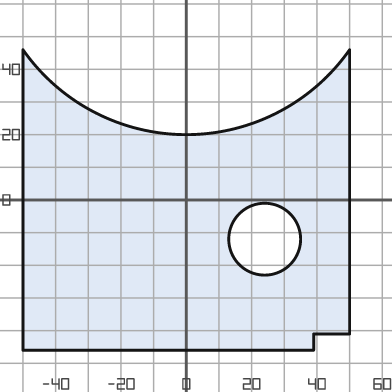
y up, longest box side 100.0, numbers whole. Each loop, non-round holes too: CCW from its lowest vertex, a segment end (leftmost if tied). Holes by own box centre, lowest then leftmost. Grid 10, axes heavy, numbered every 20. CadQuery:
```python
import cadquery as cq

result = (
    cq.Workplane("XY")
    .moveTo(-50.0, -46.0)
    .lineTo(39.0, -46.0)
    .lineTo(39.0, -41.0)
    .lineTo(50.0, -41.0)
    .lineTo(50.0, 46.0)
    .threePointArc((0.0, 20.0), (-50.0, 46.0))
    .close()
    .moveTo(24.0, -12.0)
    .circle(11.0)
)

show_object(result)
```